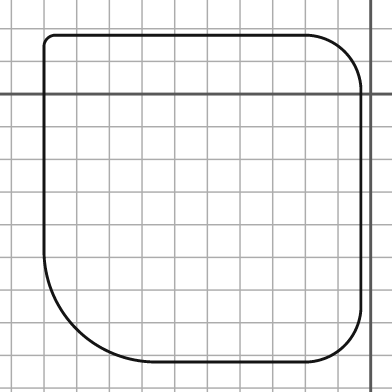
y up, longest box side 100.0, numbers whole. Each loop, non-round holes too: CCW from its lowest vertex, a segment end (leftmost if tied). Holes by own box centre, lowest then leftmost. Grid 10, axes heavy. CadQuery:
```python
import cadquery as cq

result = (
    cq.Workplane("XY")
    .moveTo(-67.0, -82.0)
    .lineTo(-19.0, -82.0)
    .threePointArc((-8.0, -77.0), (-3.0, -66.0))
    .lineTo(-3.0, 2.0)
    .threePointArc((-8.0, 13.0), (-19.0, 18.0))
    .lineTo(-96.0, 18.0)
    .threePointArc((-99.0, 17.0), (-100.0, 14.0))
    .lineTo(-100.0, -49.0)
    .threePointArc((-90.0, -72.0), (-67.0, -82.0))
    .close()
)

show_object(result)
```